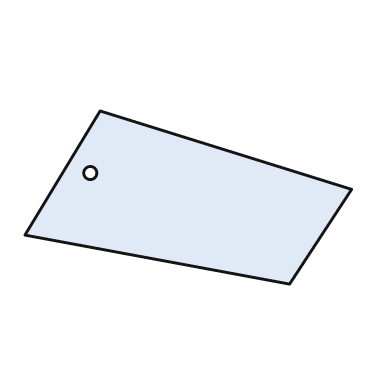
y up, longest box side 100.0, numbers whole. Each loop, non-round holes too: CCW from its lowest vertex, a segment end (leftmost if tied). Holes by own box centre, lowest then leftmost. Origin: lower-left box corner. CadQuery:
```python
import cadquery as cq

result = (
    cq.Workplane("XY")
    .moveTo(81.0, 0.0)
    .lineTo(100.0, 29.0)
    .lineTo(23.0, 53.0)
    .lineTo(0.0, 15.0)
    .close()
    .moveTo(20.0, 34.0)
    .circle(2.0)
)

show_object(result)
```